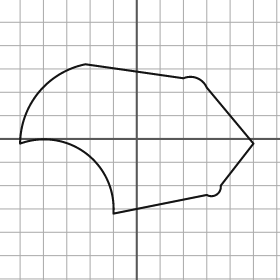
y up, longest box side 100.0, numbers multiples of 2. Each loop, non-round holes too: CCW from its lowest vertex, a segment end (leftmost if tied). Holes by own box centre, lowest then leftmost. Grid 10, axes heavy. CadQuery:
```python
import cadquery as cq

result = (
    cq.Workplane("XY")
    .moveTo(-10.0, -32.0)
    .lineTo(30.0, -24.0)
    .threePointArc((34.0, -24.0), (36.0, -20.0))
    .lineTo(50.0, -2.0)
    .lineTo(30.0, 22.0)
    .threePointArc((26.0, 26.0), (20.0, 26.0))
    .lineTo(-22.0, 32.0)
    .threePointArc((-42.0, 20.0), (-50.0, -2.0))
    .threePointArc((-22.0, -6.0), (-10.0, -32.0))
    .close()
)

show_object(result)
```